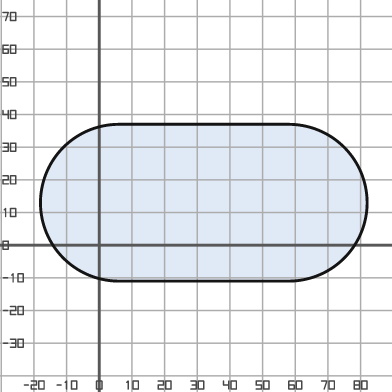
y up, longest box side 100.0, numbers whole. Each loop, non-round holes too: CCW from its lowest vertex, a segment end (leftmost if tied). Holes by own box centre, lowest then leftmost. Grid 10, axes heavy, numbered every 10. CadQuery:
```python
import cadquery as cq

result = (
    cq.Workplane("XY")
    .moveTo(6.0, -11.0)
    .lineTo(58.0, -11.0)
    .threePointArc((82.0, 13.0), (58.0, 37.0))
    .lineTo(6.0, 37.0)
    .threePointArc((-18.0, 13.0), (6.0, -11.0))
    .close()
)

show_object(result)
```